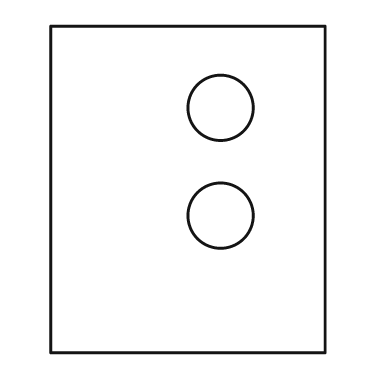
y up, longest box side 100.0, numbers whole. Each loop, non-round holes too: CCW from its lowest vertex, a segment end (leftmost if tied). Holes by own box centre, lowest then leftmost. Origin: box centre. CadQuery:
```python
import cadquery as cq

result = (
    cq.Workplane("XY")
    .moveTo(-42.0, -50.0)
    .lineTo(42.0, -50.0)
    .lineTo(42.0, 50.0)
    .lineTo(-42.0, 50.0)
    .close()
    .moveTo(10.0, -8.0)
    .circle(10.0)
    .moveTo(10.0, 25.0)
    .circle(10.0)
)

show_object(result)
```